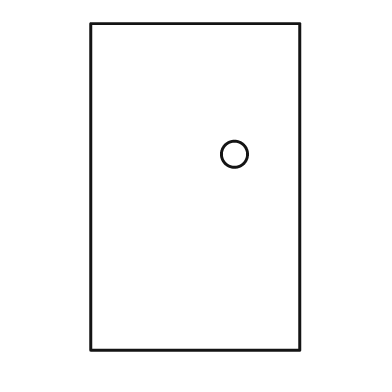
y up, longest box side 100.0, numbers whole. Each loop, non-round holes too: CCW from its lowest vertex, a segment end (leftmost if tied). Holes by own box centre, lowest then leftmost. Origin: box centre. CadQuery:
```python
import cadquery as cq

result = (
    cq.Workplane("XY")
    .moveTo(-32.0, -50.0)
    .lineTo(32.0, -50.0)
    .lineTo(32.0, 50.0)
    .lineTo(-32.0, 50.0)
    .close()
    .moveTo(12.0, 10.0)
    .circle(4.0)
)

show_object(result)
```